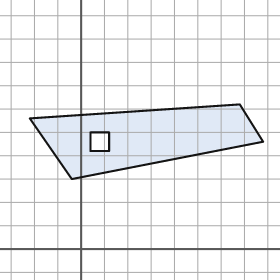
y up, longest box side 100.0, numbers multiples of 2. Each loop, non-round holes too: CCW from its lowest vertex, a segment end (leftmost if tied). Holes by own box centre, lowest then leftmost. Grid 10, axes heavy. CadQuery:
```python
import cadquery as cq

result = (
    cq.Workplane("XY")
    .moveTo(-4.0, 30.0)
    .lineTo(78.0, 46.0)
    .lineTo(68.0, 62.0)
    .lineTo(-22.0, 56.0)
    .close()
    .moveTo(4.0, 42.0)
    .lineTo(12.0, 42.0)
    .lineTo(12.0, 50.0)
    .lineTo(4.0, 50.0)
    .close()
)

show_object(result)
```